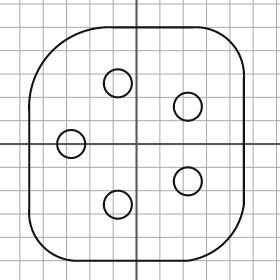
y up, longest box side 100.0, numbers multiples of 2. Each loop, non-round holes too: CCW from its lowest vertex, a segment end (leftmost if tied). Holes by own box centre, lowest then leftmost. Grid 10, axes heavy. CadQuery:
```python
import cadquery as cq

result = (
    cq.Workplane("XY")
    .moveTo(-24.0, -50.0)
    .lineTo(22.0, -50.0)
    .threePointArc((38.0, -42.0), (46.0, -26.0))
    .lineTo(46.0, 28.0)
    .threePointArc((40.0, 44.0), (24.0, 50.0))
    .lineTo(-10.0, 50.0)
    .threePointArc((-36.0, 40.0), (-46.0, 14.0))
    .lineTo(-46.0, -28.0)
    .threePointArc((-40.0, -44.0), (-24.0, -50.0))
    .close()
    .moveTo(-8.0, -26.0)
    .circle(6.0)
    .moveTo(22.0, -16.0)
    .circle(6.0)
    .moveTo(-28.0, 0.0)
    .circle(6.0)
    .moveTo(22.0, 16.0)
    .circle(6.0)
    .moveTo(-8.0, 26.0)
    .circle(6.0)
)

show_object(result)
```